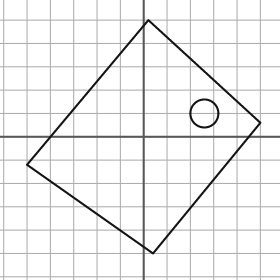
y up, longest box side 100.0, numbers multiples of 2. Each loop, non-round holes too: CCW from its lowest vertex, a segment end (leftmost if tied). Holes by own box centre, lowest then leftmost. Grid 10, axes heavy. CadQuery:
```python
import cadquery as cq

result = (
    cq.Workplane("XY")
    .moveTo(4.0, -50.0)
    .lineTo(50.0, 6.0)
    .lineTo(2.0, 50.0)
    .lineTo(-50.0, -12.0)
    .close()
    .moveTo(26.0, 10.0)
    .circle(6.0)
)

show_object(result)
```